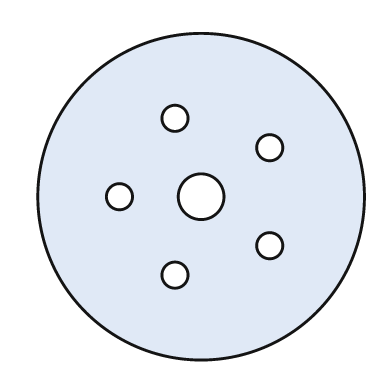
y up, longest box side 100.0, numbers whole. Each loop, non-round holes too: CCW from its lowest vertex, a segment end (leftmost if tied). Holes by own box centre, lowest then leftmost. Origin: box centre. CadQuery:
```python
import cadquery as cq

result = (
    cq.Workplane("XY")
    .moveTo(0.0, 0.0)
    .circle(50.0)
    .moveTo(-8.0, -24.0)
    .circle(4.0)
    .moveTo(21.0, -15.0)
    .circle(4.0)
    .moveTo(-25.0, 0.0)
    .circle(4.0)
    .moveTo(0.0, 0.0)
    .circle(7.0)
    .moveTo(21.0, 15.0)
    .circle(4.0)
    .moveTo(-8.0, 24.0)
    .circle(4.0)
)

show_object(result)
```